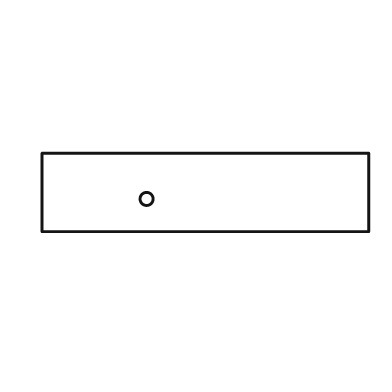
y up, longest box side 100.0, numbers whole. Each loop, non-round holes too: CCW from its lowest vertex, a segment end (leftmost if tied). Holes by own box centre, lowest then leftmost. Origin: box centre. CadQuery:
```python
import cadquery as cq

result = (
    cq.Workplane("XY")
    .moveTo(-50.0, -12.0)
    .lineTo(50.0, -12.0)
    .lineTo(50.0, 12.0)
    .lineTo(-50.0, 12.0)
    .close()
    .moveTo(-18.0, -2.0)
    .circle(2.0)
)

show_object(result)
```